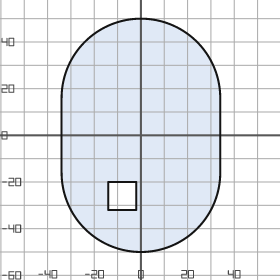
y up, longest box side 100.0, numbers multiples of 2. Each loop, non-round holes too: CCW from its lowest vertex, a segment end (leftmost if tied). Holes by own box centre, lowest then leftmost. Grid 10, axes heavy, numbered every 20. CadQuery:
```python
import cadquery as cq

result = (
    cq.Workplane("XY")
    .moveTo(-34.0, -16.0)
    .threePointArc((0.0, -50.0), (34.0, -16.0))
    .lineTo(34.0, 16.0)
    .threePointArc((0.0, 50.0), (-34.0, 16.0))
    .close()
    .moveTo(-14.0, -32.0)
    .lineTo(-2.0, -32.0)
    .lineTo(-2.0, -20.0)
    .lineTo(-14.0, -20.0)
    .close()
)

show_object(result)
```